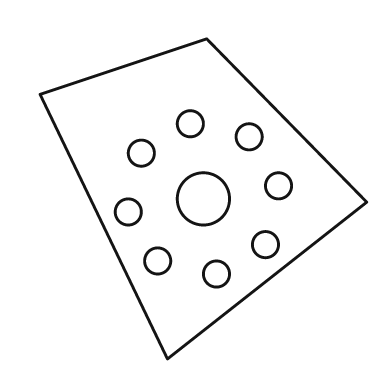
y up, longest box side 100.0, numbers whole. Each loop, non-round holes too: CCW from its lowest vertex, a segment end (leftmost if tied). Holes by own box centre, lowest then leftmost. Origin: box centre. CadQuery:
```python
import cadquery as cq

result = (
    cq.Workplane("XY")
    .moveTo(-11.0, -49.0)
    .lineTo(50.0, -1.0)
    .lineTo(1.0, 49.0)
    .lineTo(-50.0, 32.0)
    .close()
    .moveTo(4.0, -23.0)
    .circle(4.0)
    .moveTo(-14.0, -19.0)
    .circle(4.0)
    .moveTo(19.0, -14.0)
    .circle(4.0)
    .moveTo(-23.0, -4.0)
    .circle(4.0)
    .moveTo(0.0, 0.0)
    .circle(8.0)
    .moveTo(23.0, 4.0)
    .circle(4.0)
    .moveTo(-19.0, 14.0)
    .circle(4.0)
    .moveTo(14.0, 19.0)
    .circle(4.0)
    .moveTo(-4.0, 23.0)
    .circle(4.0)
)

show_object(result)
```